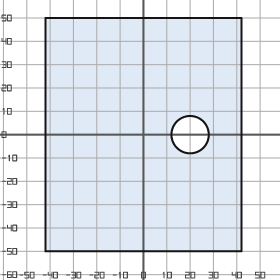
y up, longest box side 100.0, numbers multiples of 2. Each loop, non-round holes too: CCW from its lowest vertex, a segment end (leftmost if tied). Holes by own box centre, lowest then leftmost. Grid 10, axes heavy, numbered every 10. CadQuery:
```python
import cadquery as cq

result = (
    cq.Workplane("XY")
    .moveTo(-42.0, -50.0)
    .lineTo(42.0, -50.0)
    .lineTo(42.0, 50.0)
    .lineTo(-42.0, 50.0)
    .close()
    .moveTo(20.0, 0.0)
    .circle(8.0)
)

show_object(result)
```